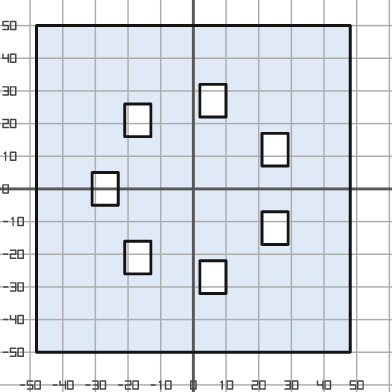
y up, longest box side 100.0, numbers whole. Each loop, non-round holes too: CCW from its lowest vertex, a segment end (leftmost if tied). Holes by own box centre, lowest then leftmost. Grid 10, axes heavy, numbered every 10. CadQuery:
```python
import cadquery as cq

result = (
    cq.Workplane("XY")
    .moveTo(-48.0, -50.0)
    .lineTo(48.0, -50.0)
    .lineTo(48.0, 50.0)
    .lineTo(-48.0, 50.0)
    .close()
    .moveTo(2.0, -32.0)
    .lineTo(10.0, -32.0)
    .lineTo(10.0, -22.0)
    .lineTo(2.0, -22.0)
    .close()
    .moveTo(-21.0, -26.0)
    .lineTo(-13.0, -26.0)
    .lineTo(-13.0, -16.0)
    .lineTo(-21.0, -16.0)
    .close()
    .moveTo(21.0, -17.0)
    .lineTo(29.0, -17.0)
    .lineTo(29.0, -7.0)
    .lineTo(21.0, -7.0)
    .close()
    .moveTo(-31.0, -5.0)
    .lineTo(-23.0, -5.0)
    .lineTo(-23.0, 5.0)
    .lineTo(-31.0, 5.0)
    .close()
    .moveTo(21.0, 7.0)
    .lineTo(29.0, 7.0)
    .lineTo(29.0, 17.0)
    .lineTo(21.0, 17.0)
    .close()
    .moveTo(-21.0, 16.0)
    .lineTo(-13.0, 16.0)
    .lineTo(-13.0, 26.0)
    .lineTo(-21.0, 26.0)
    .close()
    .moveTo(2.0, 22.0)
    .lineTo(10.0, 22.0)
    .lineTo(10.0, 32.0)
    .lineTo(2.0, 32.0)
    .close()
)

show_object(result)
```